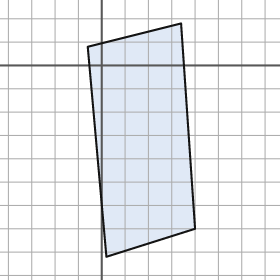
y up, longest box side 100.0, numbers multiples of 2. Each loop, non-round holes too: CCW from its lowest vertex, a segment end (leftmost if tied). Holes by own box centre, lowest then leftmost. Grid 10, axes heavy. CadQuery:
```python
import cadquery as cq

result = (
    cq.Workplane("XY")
    .moveTo(2.0, -82.0)
    .lineTo(40.0, -70.0)
    .lineTo(34.0, 18.0)
    .lineTo(-6.0, 8.0)
    .close()
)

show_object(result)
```